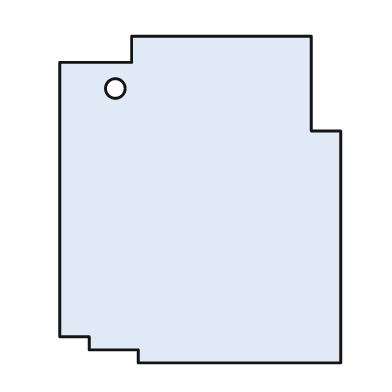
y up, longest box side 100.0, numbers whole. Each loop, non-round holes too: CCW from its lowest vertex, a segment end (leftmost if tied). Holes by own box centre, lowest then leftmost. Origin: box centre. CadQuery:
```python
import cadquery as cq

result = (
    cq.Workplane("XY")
    .moveTo(-19.0, -50.0)
    .lineTo(43.0, -50.0)
    .lineTo(43.0, 21.0)
    .lineTo(34.0, 21.0)
    .lineTo(34.0, 50.0)
    .lineTo(-21.0, 50.0)
    .lineTo(-21.0, 42.0)
    .lineTo(-43.0, 42.0)
    .lineTo(-43.0, -42.0)
    .lineTo(-34.0, -42.0)
    .lineTo(-34.0, -46.0)
    .lineTo(-19.0, -46.0)
    .close()
    .moveTo(-26.0, 34.0)
    .circle(3.0)
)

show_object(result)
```